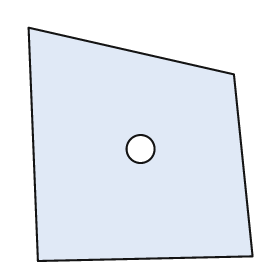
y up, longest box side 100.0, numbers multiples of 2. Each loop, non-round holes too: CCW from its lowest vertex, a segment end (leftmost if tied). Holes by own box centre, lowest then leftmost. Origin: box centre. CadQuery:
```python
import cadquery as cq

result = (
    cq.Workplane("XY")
    .moveTo(-44.0, -50.0)
    .lineTo(48.0, -48.0)
    .lineTo(40.0, 30.0)
    .lineTo(-48.0, 50.0)
    .close()
    .moveTo(0.0, -2.0)
    .circle(6.0)
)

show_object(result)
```